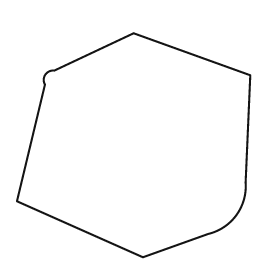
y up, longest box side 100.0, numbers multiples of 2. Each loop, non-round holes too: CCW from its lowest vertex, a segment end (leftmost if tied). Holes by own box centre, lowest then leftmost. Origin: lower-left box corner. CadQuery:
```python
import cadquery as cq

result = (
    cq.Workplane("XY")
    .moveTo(54.0, 0.0)
    .lineTo(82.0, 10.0)
    .threePointArc((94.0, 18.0), (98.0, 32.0))
    .lineTo(100.0, 78.0)
    .lineTo(50.0, 96.0)
    .lineTo(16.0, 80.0)
    .threePointArc((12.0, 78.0), (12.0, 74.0))
    .lineTo(0.0, 24.0)
    .close()
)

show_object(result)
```